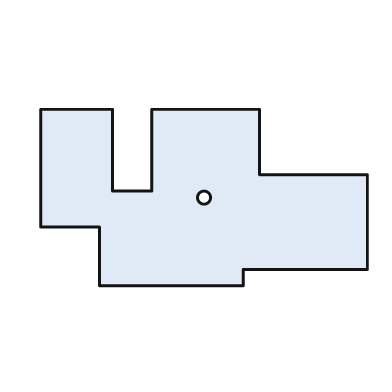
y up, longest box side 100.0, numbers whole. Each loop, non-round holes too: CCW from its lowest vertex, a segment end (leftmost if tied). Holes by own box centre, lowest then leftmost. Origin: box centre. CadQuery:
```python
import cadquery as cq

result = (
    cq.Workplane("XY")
    .moveTo(-32.0, -27.0)
    .lineTo(12.0, -27.0)
    .lineTo(12.0, -22.0)
    .lineTo(50.0, -22.0)
    .lineTo(50.0, 7.0)
    .lineTo(17.0, 7.0)
    .lineTo(17.0, 27.0)
    .lineTo(-16.0, 27.0)
    .lineTo(-16.0, 2.0)
    .lineTo(-28.0, 2.0)
    .lineTo(-28.0, 27.0)
    .lineTo(-50.0, 27.0)
    .lineTo(-50.0, -9.0)
    .lineTo(-32.0, -9.0)
    .close()
    .moveTo(0.0, 0.0)
    .circle(2.0)
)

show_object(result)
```